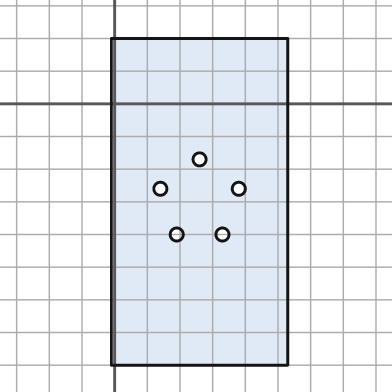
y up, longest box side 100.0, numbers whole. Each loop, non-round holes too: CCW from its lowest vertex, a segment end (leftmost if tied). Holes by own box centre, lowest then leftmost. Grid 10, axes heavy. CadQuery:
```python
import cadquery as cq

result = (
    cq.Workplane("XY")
    .moveTo(-1.0, -80.0)
    .lineTo(53.0, -80.0)
    .lineTo(53.0, 20.0)
    .lineTo(-1.0, 20.0)
    .close()
    .moveTo(19.0, -40.0)
    .circle(2.0)
    .moveTo(33.0, -40.0)
    .circle(2.0)
    .moveTo(14.0, -26.0)
    .circle(2.0)
    .moveTo(38.0, -26.0)
    .circle(2.0)
    .moveTo(26.0, -17.0)
    .circle(2.0)
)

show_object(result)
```